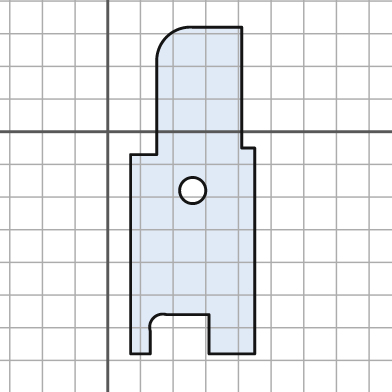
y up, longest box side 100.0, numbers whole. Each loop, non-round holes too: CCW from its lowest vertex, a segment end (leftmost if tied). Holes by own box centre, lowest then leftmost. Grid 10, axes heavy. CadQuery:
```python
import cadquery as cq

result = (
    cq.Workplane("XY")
    .moveTo(7.0, -68.0)
    .lineTo(13.0, -68.0)
    .lineTo(13.0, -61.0)
    .threePointArc((14.0, -57.0), (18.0, -56.0))
    .lineTo(31.0, -56.0)
    .lineTo(31.0, -68.0)
    .lineTo(45.0, -68.0)
    .lineTo(45.0, -5.0)
    .lineTo(41.0, -5.0)
    .lineTo(41.0, 32.0)
    .lineTo(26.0, 32.0)
    .threePointArc((18.0, 29.0), (15.0, 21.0))
    .lineTo(15.0, -7.0)
    .lineTo(7.0, -7.0)
    .close()
    .moveTo(26.0, -18.0)
    .circle(4.0)
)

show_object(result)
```